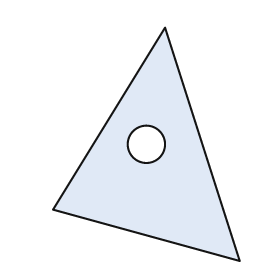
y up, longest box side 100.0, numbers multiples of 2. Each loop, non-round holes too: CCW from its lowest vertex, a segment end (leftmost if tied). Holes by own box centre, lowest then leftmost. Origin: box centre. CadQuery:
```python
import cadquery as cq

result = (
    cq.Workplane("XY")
    .moveTo(40.0, -50.0)
    .lineTo(8.0, 50.0)
    .lineTo(-40.0, -28.0)
    .close()
    .moveTo(0.0, 0.0)
    .circle(8.0)
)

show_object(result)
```